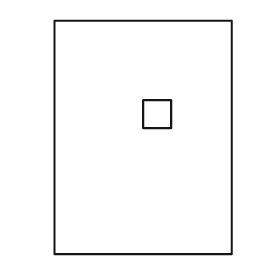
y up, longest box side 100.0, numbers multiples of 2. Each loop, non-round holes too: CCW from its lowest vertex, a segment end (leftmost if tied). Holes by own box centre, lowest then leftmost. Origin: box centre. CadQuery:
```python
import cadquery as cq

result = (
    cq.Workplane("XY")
    .moveTo(-38.0, -50.0)
    .lineTo(38.0, -50.0)
    .lineTo(38.0, 50.0)
    .lineTo(-38.0, 50.0)
    .close()
    .moveTo(0.0, 4.0)
    .lineTo(12.0, 4.0)
    .lineTo(12.0, 16.0)
    .lineTo(0.0, 16.0)
    .close()
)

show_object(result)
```